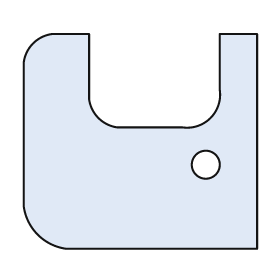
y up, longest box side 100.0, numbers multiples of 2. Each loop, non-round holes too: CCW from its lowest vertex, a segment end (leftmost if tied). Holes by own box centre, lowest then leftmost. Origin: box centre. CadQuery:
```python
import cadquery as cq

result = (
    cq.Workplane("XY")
    .moveTo(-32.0, -46.0)
    .lineTo(50.0, -46.0)
    .lineTo(50.0, 46.0)
    .lineTo(34.0, 46.0)
    .lineTo(34.0, 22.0)
    .threePointArc((30.0, 10.0), (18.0, 6.0))
    .lineTo(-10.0, 6.0)
    .threePointArc((-18.0, 10.0), (-22.0, 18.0))
    .lineTo(-22.0, 46.0)
    .lineTo(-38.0, 46.0)
    .threePointArc((-46.0, 42.0), (-50.0, 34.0))
    .lineTo(-50.0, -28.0)
    .threePointArc((-44.0, -40.0), (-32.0, -46.0))
    .close()
    .moveTo(28.0, -10.0)
    .circle(6.0)
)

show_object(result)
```